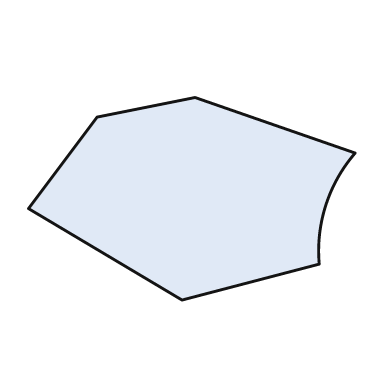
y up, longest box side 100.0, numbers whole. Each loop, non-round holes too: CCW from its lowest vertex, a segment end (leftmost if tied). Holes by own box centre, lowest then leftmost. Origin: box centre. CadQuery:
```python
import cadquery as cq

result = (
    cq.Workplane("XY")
    .moveTo(-3.0, -31.0)
    .lineTo(39.0, -20.0)
    .threePointArc((41.0, -2.0), (50.0, 14.0))
    .lineTo(1.0, 31.0)
    .lineTo(-29.0, 25.0)
    .lineTo(-50.0, -3.0)
    .close()
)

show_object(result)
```